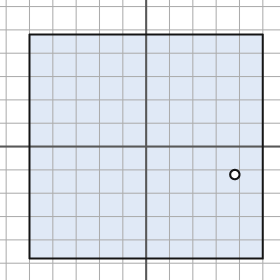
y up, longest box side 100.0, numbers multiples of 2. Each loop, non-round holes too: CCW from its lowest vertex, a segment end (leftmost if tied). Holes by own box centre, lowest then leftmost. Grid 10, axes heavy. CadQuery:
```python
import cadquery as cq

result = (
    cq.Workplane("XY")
    .moveTo(-50.0, -48.0)
    .lineTo(50.0, -48.0)
    .lineTo(50.0, 48.0)
    .lineTo(-50.0, 48.0)
    .close()
    .moveTo(38.0, -12.0)
    .circle(2.0)
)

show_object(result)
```